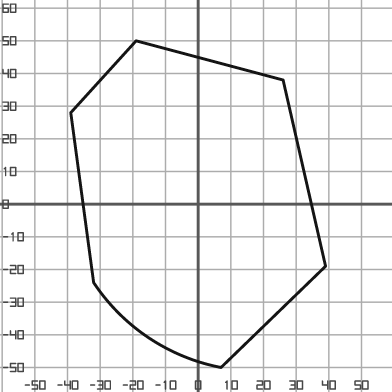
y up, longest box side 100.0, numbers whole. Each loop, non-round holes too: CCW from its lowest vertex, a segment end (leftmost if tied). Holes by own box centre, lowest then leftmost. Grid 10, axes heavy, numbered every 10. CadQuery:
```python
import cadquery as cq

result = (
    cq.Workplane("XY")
    .moveTo(7.0, -50.0)
    .lineTo(39.0, -19.0)
    .lineTo(26.0, 38.0)
    .lineTo(-19.0, 50.0)
    .lineTo(-39.0, 28.0)
    .lineTo(-32.0, -24.0)
    .threePointArc((-15.0, -41.0), (7.0, -50.0))
    .close()
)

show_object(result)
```